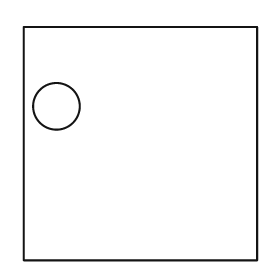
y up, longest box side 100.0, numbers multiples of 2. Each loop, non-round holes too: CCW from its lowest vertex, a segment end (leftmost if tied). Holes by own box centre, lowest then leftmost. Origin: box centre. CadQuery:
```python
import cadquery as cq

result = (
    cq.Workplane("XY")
    .moveTo(-50.0, -50.0)
    .lineTo(50.0, -50.0)
    .lineTo(50.0, 50.0)
    .lineTo(-50.0, 50.0)
    .close()
    .moveTo(-36.0, 16.0)
    .circle(10.0)
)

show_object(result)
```